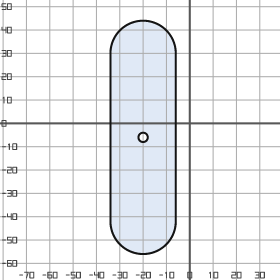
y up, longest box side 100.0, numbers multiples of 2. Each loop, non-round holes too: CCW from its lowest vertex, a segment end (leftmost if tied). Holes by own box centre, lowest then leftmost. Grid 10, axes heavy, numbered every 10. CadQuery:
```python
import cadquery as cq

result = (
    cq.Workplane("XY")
    .moveTo(-34.0, -42.0)
    .threePointArc((-20.0, -56.0), (-6.0, -42.0))
    .lineTo(-6.0, 30.0)
    .threePointArc((-20.0, 44.0), (-34.0, 30.0))
    .close()
    .moveTo(-20.0, -6.0)
    .circle(2.0)
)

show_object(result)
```